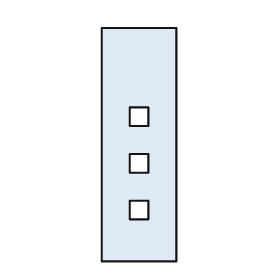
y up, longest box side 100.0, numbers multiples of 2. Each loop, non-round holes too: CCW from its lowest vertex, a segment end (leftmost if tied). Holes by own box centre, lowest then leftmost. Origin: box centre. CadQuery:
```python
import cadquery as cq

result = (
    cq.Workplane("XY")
    .moveTo(-16.0, -50.0)
    .lineTo(16.0, -50.0)
    .lineTo(16.0, 50.0)
    .lineTo(-16.0, 50.0)
    .close()
    .moveTo(-4.0, -32.0)
    .lineTo(4.0, -32.0)
    .lineTo(4.0, -24.0)
    .lineTo(-4.0, -24.0)
    .close()
    .moveTo(-4.0, -12.0)
    .lineTo(4.0, -12.0)
    .lineTo(4.0, -4.0)
    .lineTo(-4.0, -4.0)
    .close()
    .moveTo(-4.0, 8.0)
    .lineTo(4.0, 8.0)
    .lineTo(4.0, 16.0)
    .lineTo(-4.0, 16.0)
    .close()
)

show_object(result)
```